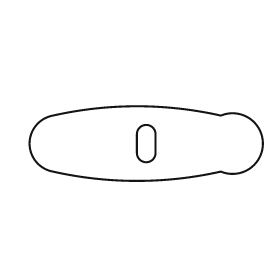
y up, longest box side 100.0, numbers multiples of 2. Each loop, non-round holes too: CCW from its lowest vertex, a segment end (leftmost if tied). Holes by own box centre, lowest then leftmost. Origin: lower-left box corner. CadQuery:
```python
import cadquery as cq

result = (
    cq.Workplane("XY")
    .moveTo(10.0, 4.0)
    .threePointArc((46.0, 0.0), (82.0, 4.0))
    .threePointArc((100.0, 16.0), (82.0, 28.0))
    .threePointArc((46.0, 32.0), (10.0, 28.0))
    .threePointArc((0.0, 16.0), (10.0, 4.0))
    .close()
    .moveTo(46.0, 12.0)
    .threePointArc((50.0, 8.0), (54.0, 12.0))
    .lineTo(54.0, 20.0)
    .threePointArc((50.0, 24.0), (46.0, 20.0))
    .close()
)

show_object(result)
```